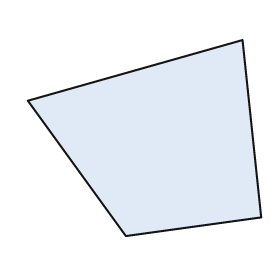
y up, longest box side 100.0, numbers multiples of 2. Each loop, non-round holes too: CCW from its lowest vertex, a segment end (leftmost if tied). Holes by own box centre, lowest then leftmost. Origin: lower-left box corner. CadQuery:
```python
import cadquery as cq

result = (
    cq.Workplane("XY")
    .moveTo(42.0, 0.0)
    .lineTo(100.0, 8.0)
    .lineTo(92.0, 84.0)
    .lineTo(0.0, 58.0)
    .close()
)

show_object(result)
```